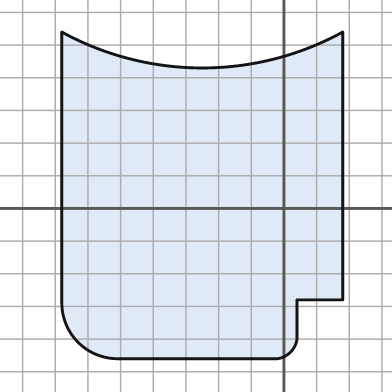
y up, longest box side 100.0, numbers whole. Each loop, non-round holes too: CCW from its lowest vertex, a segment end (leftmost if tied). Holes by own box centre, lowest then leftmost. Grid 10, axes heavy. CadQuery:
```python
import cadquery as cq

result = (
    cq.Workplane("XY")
    .moveTo(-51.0, -46.0)
    .lineTo(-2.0, -46.0)
    .threePointArc((2.0, -44.0), (4.0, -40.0))
    .lineTo(4.0, -28.0)
    .lineTo(18.0, -28.0)
    .lineTo(18.0, 54.0)
    .threePointArc((-25.0, 43.0), (-68.0, 54.0))
    .lineTo(-68.0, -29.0)
    .threePointArc((-63.0, -41.0), (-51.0, -46.0))
    .close()
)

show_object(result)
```